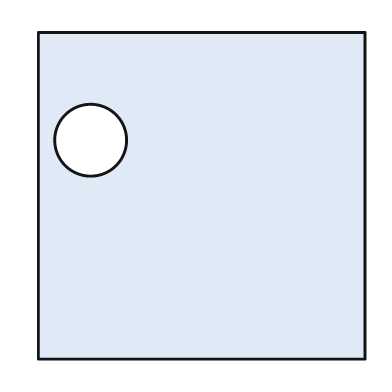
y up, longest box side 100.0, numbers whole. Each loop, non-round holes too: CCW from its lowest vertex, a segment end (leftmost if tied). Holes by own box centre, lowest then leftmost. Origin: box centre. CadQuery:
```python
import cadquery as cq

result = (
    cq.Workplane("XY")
    .moveTo(-50.0, -50.0)
    .lineTo(50.0, -50.0)
    .lineTo(50.0, 50.0)
    .lineTo(-50.0, 50.0)
    .close()
    .moveTo(-34.0, 17.0)
    .circle(11.0)
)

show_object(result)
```